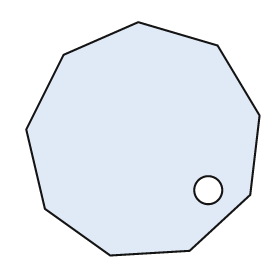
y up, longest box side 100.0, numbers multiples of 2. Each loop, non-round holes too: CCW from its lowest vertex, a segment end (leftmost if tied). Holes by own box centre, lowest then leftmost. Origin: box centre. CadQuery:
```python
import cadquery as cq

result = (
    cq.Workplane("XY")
    .moveTo(-14.0, -50.0)
    .lineTo(20.0, -48.0)
    .lineTo(46.0, -24.0)
    .lineTo(50.0, 10.0)
    .lineTo(32.0, 40.0)
    .lineTo(-2.0, 50.0)
    .lineTo(-34.0, 36.0)
    .lineTo(-50.0, 4.0)
    .lineTo(-42.0, -30.0)
    .close()
    .moveTo(28.0, -22.0)
    .circle(6.0)
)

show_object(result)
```